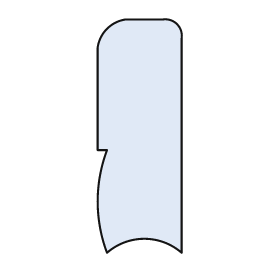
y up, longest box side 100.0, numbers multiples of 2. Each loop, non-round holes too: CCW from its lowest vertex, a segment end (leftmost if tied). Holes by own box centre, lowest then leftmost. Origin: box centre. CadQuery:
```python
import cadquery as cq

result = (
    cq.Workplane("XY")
    .moveTo(-14.0, -50.0)
    .threePointArc((2.0, -44.0), (18.0, -50.0))
    .lineTo(18.0, 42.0)
    .threePointArc((16.0, 48.0), (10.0, 50.0))
    .lineTo(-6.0, 50.0)
    .threePointArc((-14.0, 46.0), (-18.0, 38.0))
    .lineTo(-18.0, -6.0)
    .lineTo(-14.0, -6.0)
    .threePointArc((-18.0, -28.0), (-14.0, -50.0))
    .close()
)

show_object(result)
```